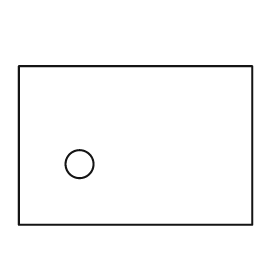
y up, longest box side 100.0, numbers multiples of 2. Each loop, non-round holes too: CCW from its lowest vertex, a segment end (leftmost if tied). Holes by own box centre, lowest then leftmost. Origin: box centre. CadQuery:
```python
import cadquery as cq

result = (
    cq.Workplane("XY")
    .moveTo(-50.0, -34.0)
    .lineTo(50.0, -34.0)
    .lineTo(50.0, 34.0)
    .lineTo(-50.0, 34.0)
    .close()
    .moveTo(-24.0, -8.0)
    .circle(6.0)
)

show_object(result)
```